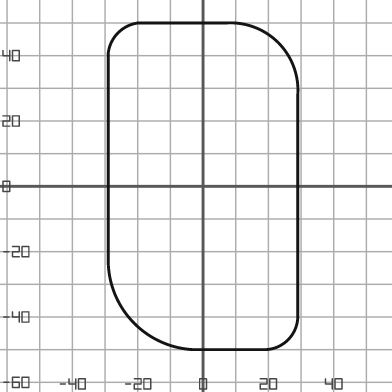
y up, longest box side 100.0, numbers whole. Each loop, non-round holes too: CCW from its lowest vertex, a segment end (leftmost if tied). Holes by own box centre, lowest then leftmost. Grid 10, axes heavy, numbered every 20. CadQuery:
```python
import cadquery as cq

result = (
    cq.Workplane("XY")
    .moveTo(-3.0, -50.0)
    .lineTo(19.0, -50.0)
    .threePointArc((26.0, -47.0), (29.0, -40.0))
    .lineTo(29.0, 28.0)
    .threePointArc((23.0, 44.0), (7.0, 50.0))
    .lineTo(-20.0, 50.0)
    .threePointArc((-26.0, 47.0), (-29.0, 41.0))
    .lineTo(-29.0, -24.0)
    .threePointArc((-21.0, -42.0), (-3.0, -50.0))
    .close()
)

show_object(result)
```